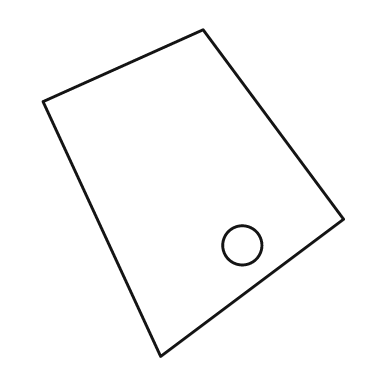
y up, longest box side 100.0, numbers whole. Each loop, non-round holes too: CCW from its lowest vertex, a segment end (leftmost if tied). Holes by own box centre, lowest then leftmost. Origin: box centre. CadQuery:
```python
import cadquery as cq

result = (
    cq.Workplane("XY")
    .moveTo(-10.0, -50.0)
    .lineTo(46.0, -8.0)
    .lineTo(3.0, 50.0)
    .lineTo(-46.0, 28.0)
    .close()
    .moveTo(15.0, -16.0)
    .circle(6.0)
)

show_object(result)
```